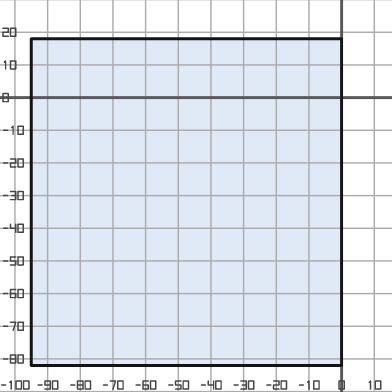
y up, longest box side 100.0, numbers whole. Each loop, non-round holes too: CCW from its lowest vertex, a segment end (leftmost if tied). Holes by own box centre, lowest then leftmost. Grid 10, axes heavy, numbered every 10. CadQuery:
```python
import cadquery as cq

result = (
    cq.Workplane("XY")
    .moveTo(-95.0, -82.0)
    .lineTo(0.0, -82.0)
    .lineTo(0.0, 18.0)
    .lineTo(-95.0, 18.0)
    .close()
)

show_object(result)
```